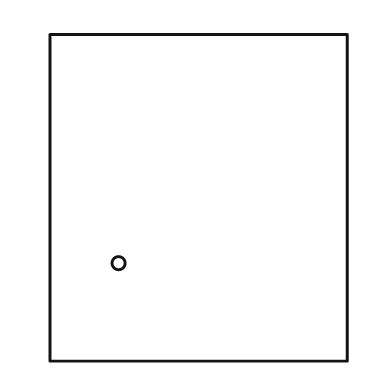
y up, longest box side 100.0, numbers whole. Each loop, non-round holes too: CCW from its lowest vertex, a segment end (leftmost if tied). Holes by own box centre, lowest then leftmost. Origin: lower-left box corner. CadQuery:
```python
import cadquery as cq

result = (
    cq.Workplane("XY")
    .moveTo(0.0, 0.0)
    .lineTo(91.0, 0.0)
    .lineTo(91.0, 100.0)
    .lineTo(0.0, 100.0)
    .close()
    .moveTo(21.0, 30.0)
    .circle(2.0)
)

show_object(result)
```